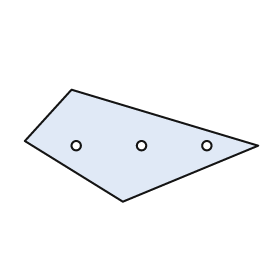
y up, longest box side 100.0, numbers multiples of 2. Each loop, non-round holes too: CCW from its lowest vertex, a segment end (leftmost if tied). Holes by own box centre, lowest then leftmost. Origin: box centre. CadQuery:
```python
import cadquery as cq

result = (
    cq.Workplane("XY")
    .moveTo(-8.0, -24.0)
    .lineTo(50.0, 0.0)
    .lineTo(-30.0, 24.0)
    .lineTo(-50.0, 2.0)
    .close()
    .moveTo(-28.0, 0.0)
    .circle(2.0)
    .moveTo(0.0, 0.0)
    .circle(2.0)
    .moveTo(28.0, 0.0)
    .circle(2.0)
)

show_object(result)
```